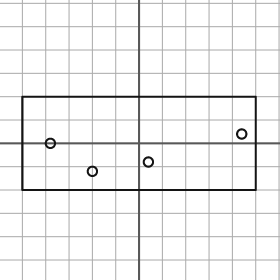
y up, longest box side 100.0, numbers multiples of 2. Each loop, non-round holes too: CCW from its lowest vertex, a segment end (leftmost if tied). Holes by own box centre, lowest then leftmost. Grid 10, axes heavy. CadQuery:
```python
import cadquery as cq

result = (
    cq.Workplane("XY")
    .moveTo(-50.0, -20.0)
    .lineTo(50.0, -20.0)
    .lineTo(50.0, 20.0)
    .lineTo(-50.0, 20.0)
    .close()
    .moveTo(-20.0, -12.0)
    .circle(2.0)
    .moveTo(4.0, -8.0)
    .circle(2.0)
    .moveTo(-38.0, 0.0)
    .circle(2.0)
    .moveTo(44.0, 4.0)
    .circle(2.0)
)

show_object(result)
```